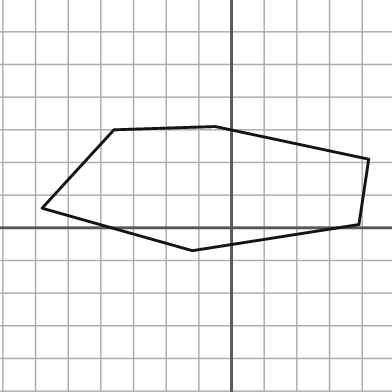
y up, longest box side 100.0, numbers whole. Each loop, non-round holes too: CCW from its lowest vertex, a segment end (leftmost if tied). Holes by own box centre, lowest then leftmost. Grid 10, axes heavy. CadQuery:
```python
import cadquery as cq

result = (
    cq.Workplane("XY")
    .moveTo(-12.0, -7.0)
    .lineTo(39.0, 1.0)
    .lineTo(42.0, 21.0)
    .lineTo(-5.0, 31.0)
    .lineTo(-36.0, 30.0)
    .lineTo(-58.0, 6.0)
    .close()
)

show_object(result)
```